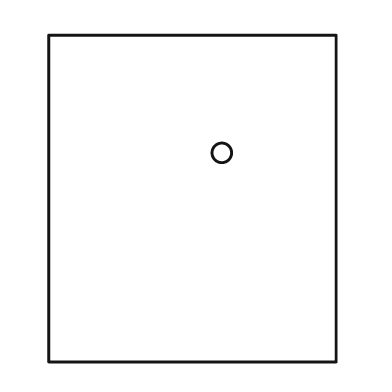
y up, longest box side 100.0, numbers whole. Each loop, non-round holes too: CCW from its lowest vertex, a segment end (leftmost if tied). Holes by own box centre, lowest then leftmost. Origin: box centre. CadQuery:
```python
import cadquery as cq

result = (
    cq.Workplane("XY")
    .moveTo(-44.0, -50.0)
    .lineTo(44.0, -50.0)
    .lineTo(44.0, 50.0)
    .lineTo(-44.0, 50.0)
    .close()
    .moveTo(9.0, 14.0)
    .circle(3.0)
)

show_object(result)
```